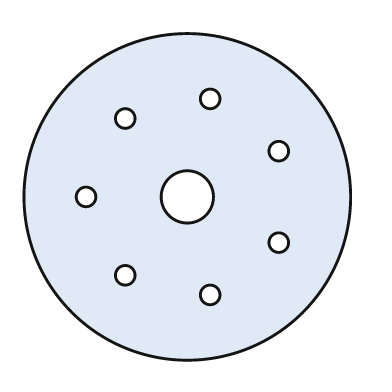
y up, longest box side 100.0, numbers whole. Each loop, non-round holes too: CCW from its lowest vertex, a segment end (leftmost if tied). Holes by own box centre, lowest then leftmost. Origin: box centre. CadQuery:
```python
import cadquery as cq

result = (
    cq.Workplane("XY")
    .moveTo(0.0, 0.0)
    .circle(50.0)
    .moveTo(7.0, -30.0)
    .circle(3.0)
    .moveTo(-19.0, -24.0)
    .circle(3.0)
    .moveTo(28.0, -14.0)
    .circle(3.0)
    .moveTo(-31.0, 0.0)
    .circle(3.0)
    .moveTo(0.0, 0.0)
    .circle(8.0)
    .moveTo(28.0, 14.0)
    .circle(3.0)
    .moveTo(-19.0, 24.0)
    .circle(3.0)
    .moveTo(7.0, 30.0)
    .circle(3.0)
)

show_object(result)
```